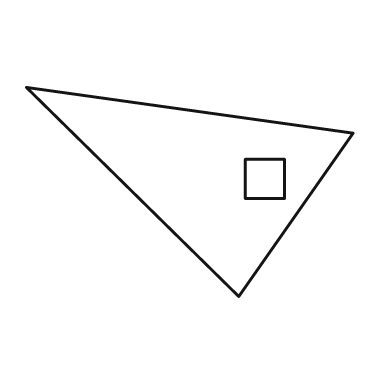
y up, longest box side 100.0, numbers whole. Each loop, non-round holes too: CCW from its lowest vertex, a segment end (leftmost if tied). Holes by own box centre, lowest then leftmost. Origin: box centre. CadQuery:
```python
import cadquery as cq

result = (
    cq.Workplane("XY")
    .moveTo(15.0, -32.0)
    .lineTo(50.0, 18.0)
    .lineTo(-50.0, 32.0)
    .close()
    .moveTo(17.0, -2.0)
    .lineTo(29.0, -2.0)
    .lineTo(29.0, 10.0)
    .lineTo(17.0, 10.0)
    .close()
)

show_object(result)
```